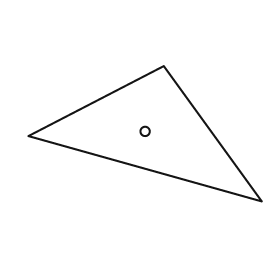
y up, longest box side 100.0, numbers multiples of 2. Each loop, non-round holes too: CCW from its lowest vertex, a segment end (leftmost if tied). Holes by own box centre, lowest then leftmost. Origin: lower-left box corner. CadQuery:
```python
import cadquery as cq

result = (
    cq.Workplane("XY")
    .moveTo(100.0, 0.0)
    .lineTo(58.0, 58.0)
    .lineTo(0.0, 28.0)
    .close()
    .moveTo(50.0, 30.0)
    .circle(2.0)
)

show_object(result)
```